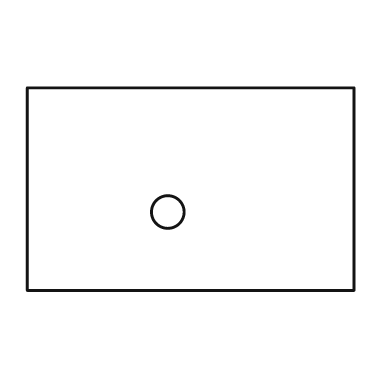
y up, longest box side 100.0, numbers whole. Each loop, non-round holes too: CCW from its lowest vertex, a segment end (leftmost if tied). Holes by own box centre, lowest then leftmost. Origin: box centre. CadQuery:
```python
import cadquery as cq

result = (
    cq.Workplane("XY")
    .moveTo(-50.0, -31.0)
    .lineTo(50.0, -31.0)
    .lineTo(50.0, 31.0)
    .lineTo(-50.0, 31.0)
    .close()
    .moveTo(-7.0, -7.0)
    .circle(5.0)
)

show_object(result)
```